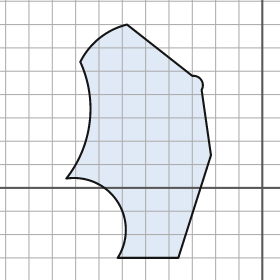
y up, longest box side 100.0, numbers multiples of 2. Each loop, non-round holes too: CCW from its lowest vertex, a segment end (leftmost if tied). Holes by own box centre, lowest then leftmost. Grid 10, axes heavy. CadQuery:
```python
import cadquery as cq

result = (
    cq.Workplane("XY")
    .moveTo(-62.0, -30.0)
    .lineTo(-36.0, -30.0)
    .lineTo(-22.0, 14.0)
    .lineTo(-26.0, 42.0)
    .threePointArc((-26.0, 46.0), (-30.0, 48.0))
    .lineTo(-58.0, 70.0)
    .threePointArc((-70.0, 64.0), (-78.0, 54.0))
    .threePointArc((-74.0, 28.0), (-84.0, 4.0))
    .threePointArc((-62.0, -6.0), (-62.0, -30.0))
    .close()
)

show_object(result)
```